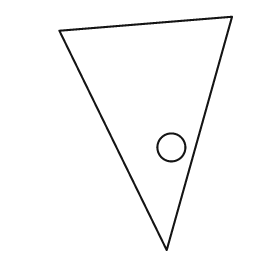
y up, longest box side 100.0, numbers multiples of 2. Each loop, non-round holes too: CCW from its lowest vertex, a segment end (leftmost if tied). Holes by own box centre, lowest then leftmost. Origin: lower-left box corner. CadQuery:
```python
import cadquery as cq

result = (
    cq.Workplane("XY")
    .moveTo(46.0, 0.0)
    .lineTo(74.0, 100.0)
    .lineTo(0.0, 94.0)
    .close()
    .moveTo(48.0, 44.0)
    .circle(6.0)
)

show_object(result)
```